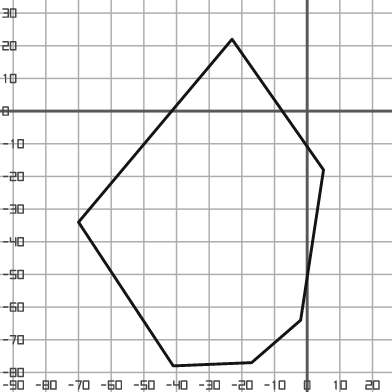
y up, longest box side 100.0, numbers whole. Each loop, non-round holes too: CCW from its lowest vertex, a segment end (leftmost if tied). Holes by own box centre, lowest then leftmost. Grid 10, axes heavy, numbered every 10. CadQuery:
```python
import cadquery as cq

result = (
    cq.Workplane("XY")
    .moveTo(-41.0, -78.0)
    .lineTo(-17.0, -77.0)
    .lineTo(-2.0, -64.0)
    .lineTo(5.0, -18.0)
    .lineTo(-23.0, 22.0)
    .lineTo(-70.0, -34.0)
    .close()
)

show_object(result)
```